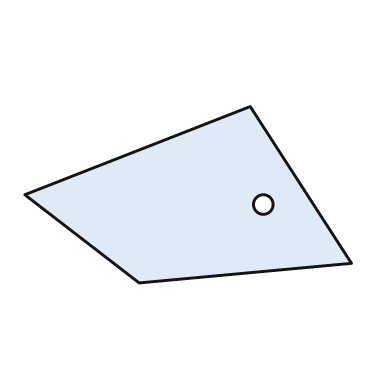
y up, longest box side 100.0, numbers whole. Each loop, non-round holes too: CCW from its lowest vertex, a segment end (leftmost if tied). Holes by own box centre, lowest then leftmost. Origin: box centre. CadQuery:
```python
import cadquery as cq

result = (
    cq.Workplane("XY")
    .moveTo(-15.0, -27.0)
    .lineTo(50.0, -21.0)
    .lineTo(19.0, 27.0)
    .lineTo(-50.0, 0.0)
    .close()
    .moveTo(23.0, -3.0)
    .circle(3.0)
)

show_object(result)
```